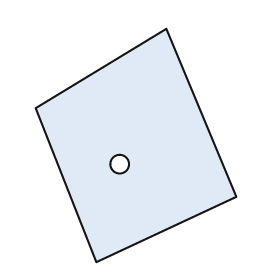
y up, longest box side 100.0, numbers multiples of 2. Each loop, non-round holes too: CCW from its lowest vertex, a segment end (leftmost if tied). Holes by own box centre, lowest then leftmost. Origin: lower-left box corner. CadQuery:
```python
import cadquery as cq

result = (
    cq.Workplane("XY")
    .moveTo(26.0, 0.0)
    .lineTo(86.0, 28.0)
    .lineTo(56.0, 100.0)
    .lineTo(0.0, 66.0)
    .close()
    .moveTo(36.0, 42.0)
    .circle(4.0)
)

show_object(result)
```